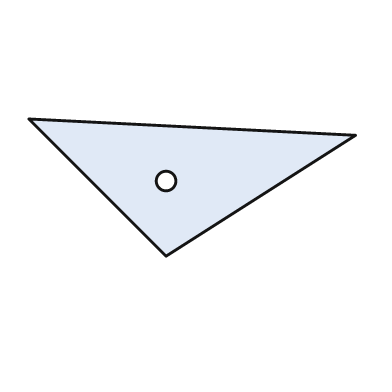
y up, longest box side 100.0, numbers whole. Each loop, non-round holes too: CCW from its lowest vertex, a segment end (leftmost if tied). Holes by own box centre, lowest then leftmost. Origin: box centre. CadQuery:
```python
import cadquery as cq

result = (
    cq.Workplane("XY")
    .moveTo(-8.0, -21.0)
    .lineTo(50.0, 16.0)
    .lineTo(-50.0, 21.0)
    .close()
    .moveTo(-8.0, 2.0)
    .circle(3.0)
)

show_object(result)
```